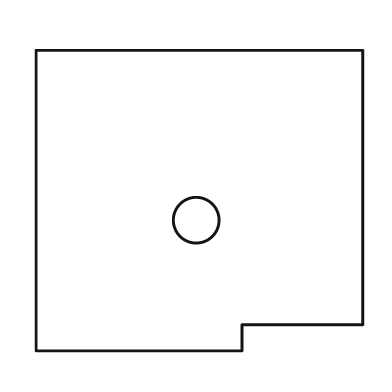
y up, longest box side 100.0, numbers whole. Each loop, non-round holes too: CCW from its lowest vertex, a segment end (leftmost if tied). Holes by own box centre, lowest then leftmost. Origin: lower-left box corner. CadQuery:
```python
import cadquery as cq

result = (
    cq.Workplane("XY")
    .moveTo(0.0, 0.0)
    .lineTo(63.0, 0.0)
    .lineTo(63.0, 8.0)
    .lineTo(100.0, 8.0)
    .lineTo(100.0, 92.0)
    .lineTo(0.0, 92.0)
    .close()
    .moveTo(49.0, 40.0)
    .circle(7.0)
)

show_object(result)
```